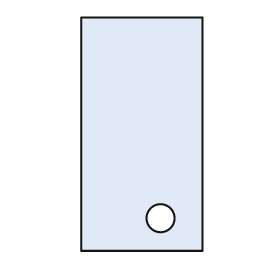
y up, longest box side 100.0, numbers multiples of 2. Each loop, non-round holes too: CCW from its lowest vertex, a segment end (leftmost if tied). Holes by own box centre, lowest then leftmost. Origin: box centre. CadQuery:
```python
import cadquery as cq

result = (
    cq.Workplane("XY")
    .moveTo(-26.0, -50.0)
    .lineTo(26.0, -50.0)
    .lineTo(26.0, 50.0)
    .lineTo(-26.0, 50.0)
    .close()
    .moveTo(8.0, -36.0)
    .circle(6.0)
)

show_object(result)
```